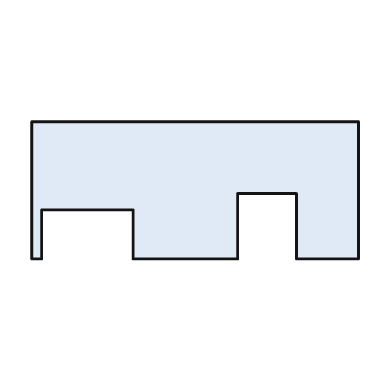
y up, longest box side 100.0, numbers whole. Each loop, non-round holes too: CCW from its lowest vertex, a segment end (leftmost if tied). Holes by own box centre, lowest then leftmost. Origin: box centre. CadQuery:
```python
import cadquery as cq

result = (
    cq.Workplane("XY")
    .moveTo(-50.0, -21.0)
    .lineTo(-47.0, -21.0)
    .lineTo(-47.0, -6.0)
    .lineTo(-19.0, -6.0)
    .lineTo(-19.0, -21.0)
    .lineTo(13.0, -21.0)
    .lineTo(13.0, -1.0)
    .lineTo(31.0, -1.0)
    .lineTo(31.0, -21.0)
    .lineTo(50.0, -21.0)
    .lineTo(50.0, 21.0)
    .lineTo(-50.0, 21.0)
    .close()
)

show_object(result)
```